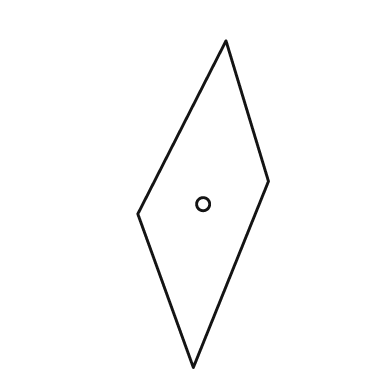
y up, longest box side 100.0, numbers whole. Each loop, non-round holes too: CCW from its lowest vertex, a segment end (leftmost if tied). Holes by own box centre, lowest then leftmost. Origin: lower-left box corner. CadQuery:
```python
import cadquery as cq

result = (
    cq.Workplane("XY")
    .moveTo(17.0, 0.0)
    .lineTo(40.0, 57.0)
    .lineTo(27.0, 100.0)
    .lineTo(0.0, 47.0)
    .close()
    .moveTo(20.0, 50.0)
    .circle(2.0)
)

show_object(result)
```